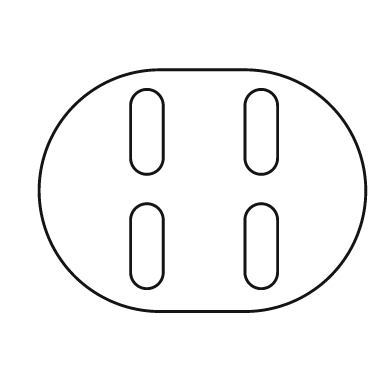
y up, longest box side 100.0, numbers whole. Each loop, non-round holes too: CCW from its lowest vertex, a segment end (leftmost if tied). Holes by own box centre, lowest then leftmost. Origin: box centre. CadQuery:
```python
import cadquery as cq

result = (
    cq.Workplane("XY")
    .moveTo(-13.0, -37.0)
    .lineTo(13.0, -37.0)
    .threePointArc((50.0, 0.0), (13.0, 37.0))
    .lineTo(-13.0, 37.0)
    .threePointArc((-50.0, 0.0), (-13.0, -37.0))
    .close()
    .moveTo(-22.0, -25.0)
    .threePointArc((-17.0, -30.0), (-12.0, -25.0))
    .lineTo(-12.0, -9.0)
    .threePointArc((-17.0, -4.0), (-22.0, -9.0))
    .close()
    .moveTo(13.0, -25.0)
    .threePointArc((18.0, -30.0), (23.0, -25.0))
    .lineTo(23.0, -9.0)
    .threePointArc((18.0, -4.0), (13.0, -9.0))
    .close()
    .moveTo(-22.0, 10.0)
    .threePointArc((-17.0, 5.0), (-12.0, 10.0))
    .lineTo(-12.0, 26.0)
    .threePointArc((-17.0, 31.0), (-22.0, 26.0))
    .close()
    .moveTo(13.0, 10.0)
    .threePointArc((18.0, 5.0), (23.0, 10.0))
    .lineTo(23.0, 26.0)
    .threePointArc((18.0, 31.0), (13.0, 26.0))
    .close()
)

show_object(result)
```